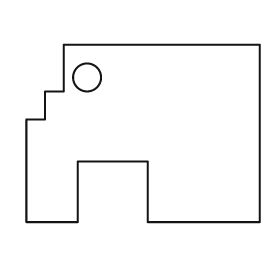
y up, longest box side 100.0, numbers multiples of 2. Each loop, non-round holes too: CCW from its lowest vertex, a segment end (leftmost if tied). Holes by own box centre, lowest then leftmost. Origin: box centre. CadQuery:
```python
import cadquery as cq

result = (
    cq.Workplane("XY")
    .moveTo(-50.0, -38.0)
    .lineTo(-28.0, -38.0)
    .lineTo(-28.0, -12.0)
    .lineTo(2.0, -12.0)
    .lineTo(2.0, -38.0)
    .lineTo(50.0, -38.0)
    .lineTo(50.0, 38.0)
    .lineTo(-34.0, 38.0)
    .lineTo(-34.0, 18.0)
    .lineTo(-42.0, 18.0)
    .lineTo(-42.0, 6.0)
    .lineTo(-50.0, 6.0)
    .close()
    .moveTo(-24.0, 24.0)
    .circle(6.0)
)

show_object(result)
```